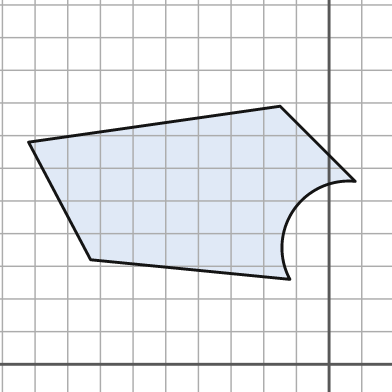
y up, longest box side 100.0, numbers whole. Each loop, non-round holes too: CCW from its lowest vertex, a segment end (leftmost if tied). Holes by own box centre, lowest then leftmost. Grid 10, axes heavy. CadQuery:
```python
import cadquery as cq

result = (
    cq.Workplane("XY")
    .moveTo(-12.0, 26.0)
    .threePointArc((-11.0, 47.0), (8.0, 56.0))
    .lineTo(-15.0, 79.0)
    .lineTo(-92.0, 68.0)
    .lineTo(-73.0, 32.0)
    .close()
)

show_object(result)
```